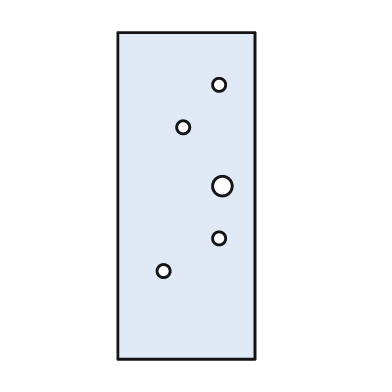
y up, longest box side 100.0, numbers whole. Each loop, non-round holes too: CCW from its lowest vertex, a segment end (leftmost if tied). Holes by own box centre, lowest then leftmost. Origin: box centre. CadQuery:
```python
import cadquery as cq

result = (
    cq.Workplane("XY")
    .moveTo(-21.0, -50.0)
    .lineTo(21.0, -50.0)
    .lineTo(21.0, 50.0)
    .lineTo(-21.0, 50.0)
    .close()
    .moveTo(-7.0, -23.0)
    .circle(2.0)
    .moveTo(10.0, -13.0)
    .circle(2.0)
    .moveTo(11.0, 3.0)
    .circle(3.0)
    .moveTo(-1.0, 21.0)
    .circle(2.0)
    .moveTo(10.0, 34.0)
    .circle(2.0)
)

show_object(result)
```